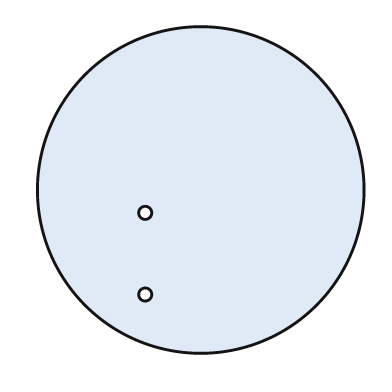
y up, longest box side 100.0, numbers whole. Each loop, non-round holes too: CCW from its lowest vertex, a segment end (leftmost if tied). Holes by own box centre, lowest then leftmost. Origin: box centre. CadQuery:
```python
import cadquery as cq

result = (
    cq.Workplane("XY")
    .moveTo(0.0, 0.0)
    .circle(50.0)
    .moveTo(-17.0, -32.0)
    .circle(2.0)
    .moveTo(-17.0, -7.0)
    .circle(2.0)
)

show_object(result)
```